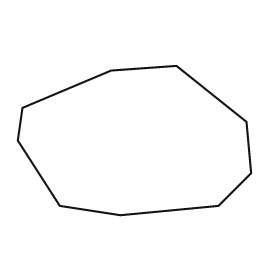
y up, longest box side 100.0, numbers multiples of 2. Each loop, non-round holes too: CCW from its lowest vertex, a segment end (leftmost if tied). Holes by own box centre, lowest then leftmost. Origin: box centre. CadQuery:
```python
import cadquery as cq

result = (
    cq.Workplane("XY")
    .moveTo(-6.0, -32.0)
    .lineTo(36.0, -28.0)
    .lineTo(50.0, -14.0)
    .lineTo(48.0, 8.0)
    .lineTo(18.0, 32.0)
    .lineTo(-10.0, 30.0)
    .lineTo(-48.0, 14.0)
    .lineTo(-50.0, 0.0)
    .lineTo(-32.0, -28.0)
    .close()
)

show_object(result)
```